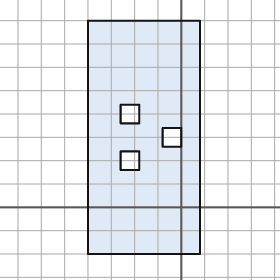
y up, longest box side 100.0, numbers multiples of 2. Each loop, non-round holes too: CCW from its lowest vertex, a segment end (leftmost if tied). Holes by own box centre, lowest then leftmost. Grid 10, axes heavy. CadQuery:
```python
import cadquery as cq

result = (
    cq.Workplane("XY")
    .moveTo(-40.0, -20.0)
    .lineTo(8.0, -20.0)
    .lineTo(8.0, 80.0)
    .lineTo(-40.0, 80.0)
    .close()
    .moveTo(-26.0, 16.0)
    .lineTo(-18.0, 16.0)
    .lineTo(-18.0, 24.0)
    .lineTo(-26.0, 24.0)
    .close()
    .moveTo(-8.0, 26.0)
    .lineTo(0.0, 26.0)
    .lineTo(0.0, 34.0)
    .lineTo(-8.0, 34.0)
    .close()
    .moveTo(-26.0, 36.0)
    .lineTo(-18.0, 36.0)
    .lineTo(-18.0, 44.0)
    .lineTo(-26.0, 44.0)
    .close()
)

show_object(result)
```